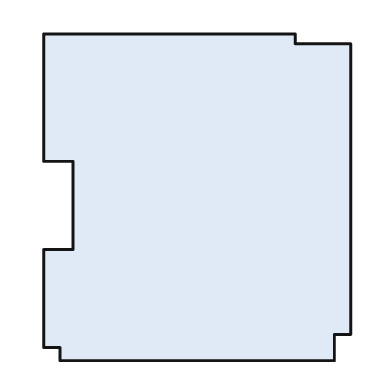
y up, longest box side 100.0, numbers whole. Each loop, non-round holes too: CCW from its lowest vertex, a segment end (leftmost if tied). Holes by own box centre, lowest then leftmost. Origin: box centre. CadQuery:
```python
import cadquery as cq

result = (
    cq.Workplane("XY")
    .moveTo(-42.0, -50.0)
    .lineTo(42.0, -50.0)
    .lineTo(42.0, -42.0)
    .lineTo(47.0, -42.0)
    .lineTo(47.0, 47.0)
    .lineTo(30.0, 47.0)
    .lineTo(30.0, 50.0)
    .lineTo(-47.0, 50.0)
    .lineTo(-47.0, 11.0)
    .lineTo(-38.0, 11.0)
    .lineTo(-38.0, -16.0)
    .lineTo(-47.0, -16.0)
    .lineTo(-47.0, -46.0)
    .lineTo(-42.0, -46.0)
    .close()
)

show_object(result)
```